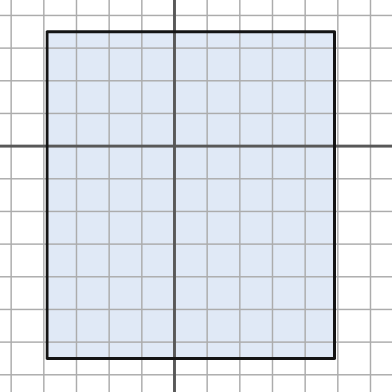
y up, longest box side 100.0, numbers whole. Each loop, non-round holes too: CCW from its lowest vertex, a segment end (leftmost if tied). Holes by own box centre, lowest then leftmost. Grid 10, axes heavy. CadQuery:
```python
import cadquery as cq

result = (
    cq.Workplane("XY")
    .moveTo(-39.0, -65.0)
    .lineTo(49.0, -65.0)
    .lineTo(49.0, 35.0)
    .lineTo(-39.0, 35.0)
    .close()
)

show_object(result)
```